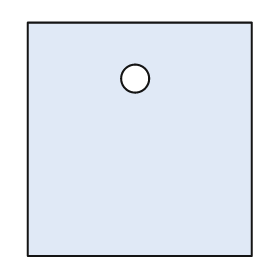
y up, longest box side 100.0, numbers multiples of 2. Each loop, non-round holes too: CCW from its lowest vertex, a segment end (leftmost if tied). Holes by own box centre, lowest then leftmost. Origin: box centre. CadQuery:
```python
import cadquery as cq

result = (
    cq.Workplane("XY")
    .moveTo(-48.0, -50.0)
    .lineTo(48.0, -50.0)
    .lineTo(48.0, 50.0)
    .lineTo(-48.0, 50.0)
    .close()
    .moveTo(-2.0, 26.0)
    .circle(6.0)
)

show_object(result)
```